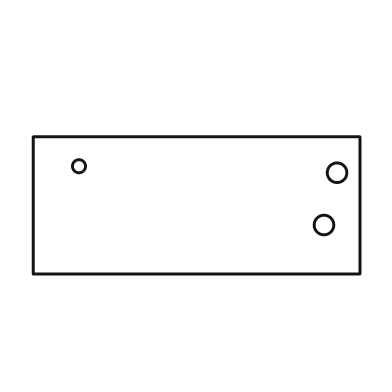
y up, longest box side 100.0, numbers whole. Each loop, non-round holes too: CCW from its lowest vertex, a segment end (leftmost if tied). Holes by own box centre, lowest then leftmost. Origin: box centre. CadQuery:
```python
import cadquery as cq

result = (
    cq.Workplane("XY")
    .moveTo(-50.0, -21.0)
    .lineTo(50.0, -21.0)
    .lineTo(50.0, 21.0)
    .lineTo(-50.0, 21.0)
    .close()
    .moveTo(39.0, -6.0)
    .circle(3.0)
    .moveTo(43.0, 10.0)
    .circle(3.0)
    .moveTo(-36.0, 12.0)
    .circle(2.0)
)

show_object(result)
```